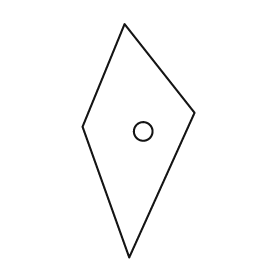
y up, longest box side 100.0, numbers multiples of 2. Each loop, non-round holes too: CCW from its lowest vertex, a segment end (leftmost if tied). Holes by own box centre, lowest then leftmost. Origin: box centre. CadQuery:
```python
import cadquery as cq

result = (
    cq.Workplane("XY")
    .moveTo(-4.0, -50.0)
    .lineTo(24.0, 12.0)
    .lineTo(-6.0, 50.0)
    .lineTo(-24.0, 6.0)
    .close()
    .moveTo(2.0, 4.0)
    .circle(4.0)
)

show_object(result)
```